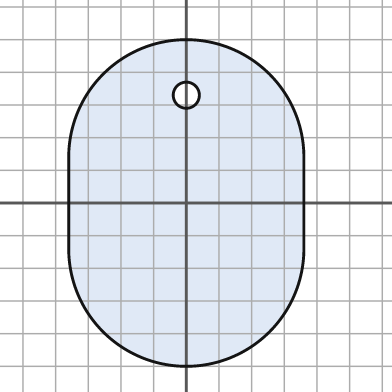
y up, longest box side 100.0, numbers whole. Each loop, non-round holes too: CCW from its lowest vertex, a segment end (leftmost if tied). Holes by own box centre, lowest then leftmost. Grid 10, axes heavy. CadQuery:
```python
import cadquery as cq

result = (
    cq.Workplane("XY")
    .moveTo(-36.0, -14.0)
    .threePointArc((0.0, -50.0), (36.0, -14.0))
    .lineTo(36.0, 14.0)
    .threePointArc((0.0, 50.0), (-36.0, 14.0))
    .close()
    .moveTo(0.0, 33.0)
    .circle(4.0)
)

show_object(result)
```